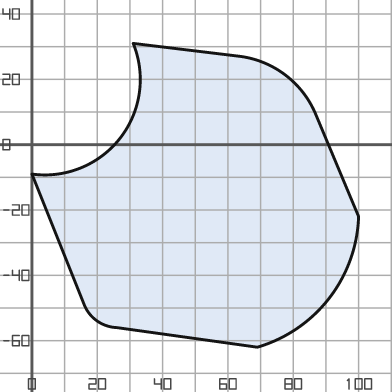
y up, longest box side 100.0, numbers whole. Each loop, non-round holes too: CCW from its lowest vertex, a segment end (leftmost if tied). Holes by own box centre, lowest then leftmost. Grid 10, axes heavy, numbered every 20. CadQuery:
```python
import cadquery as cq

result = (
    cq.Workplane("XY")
    .moveTo(69.0, -62.0)
    .threePointArc((91.0, -47.0), (100.0, -22.0))
    .lineTo(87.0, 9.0)
    .threePointArc((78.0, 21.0), (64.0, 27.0))
    .lineTo(31.0, 31.0)
    .threePointArc((27.0, 2.0), (0.0, -9.0))
    .lineTo(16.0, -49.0)
    .threePointArc((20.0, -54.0), (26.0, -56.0))
    .close()
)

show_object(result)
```